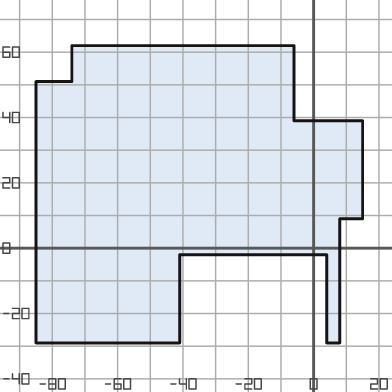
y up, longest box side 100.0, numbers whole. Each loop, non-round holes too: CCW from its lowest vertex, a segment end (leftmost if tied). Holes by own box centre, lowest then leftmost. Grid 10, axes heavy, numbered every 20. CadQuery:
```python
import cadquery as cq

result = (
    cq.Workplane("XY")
    .moveTo(-85.0, -29.0)
    .lineTo(-41.0, -29.0)
    .lineTo(-41.0, -2.0)
    .lineTo(4.0, -2.0)
    .lineTo(4.0, -29.0)
    .lineTo(8.0, -29.0)
    .lineTo(8.0, 9.0)
    .lineTo(15.0, 9.0)
    .lineTo(15.0, 39.0)
    .lineTo(-6.0, 39.0)
    .lineTo(-6.0, 62.0)
    .lineTo(-74.0, 62.0)
    .lineTo(-74.0, 51.0)
    .lineTo(-85.0, 51.0)
    .close()
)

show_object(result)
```